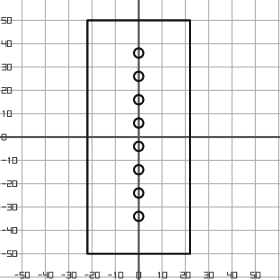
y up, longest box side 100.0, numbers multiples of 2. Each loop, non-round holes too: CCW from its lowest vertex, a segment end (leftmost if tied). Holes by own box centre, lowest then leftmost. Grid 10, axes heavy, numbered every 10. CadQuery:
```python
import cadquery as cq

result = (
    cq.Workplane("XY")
    .moveTo(-22.0, -50.0)
    .lineTo(22.0, -50.0)
    .lineTo(22.0, 50.0)
    .lineTo(-22.0, 50.0)
    .close()
    .moveTo(0.0, -34.0)
    .circle(2.0)
    .moveTo(0.0, -24.0)
    .circle(2.0)
    .moveTo(0.0, -14.0)
    .circle(2.0)
    .moveTo(0.0, -4.0)
    .circle(2.0)
    .moveTo(0.0, 6.0)
    .circle(2.0)
    .moveTo(0.0, 16.0)
    .circle(2.0)
    .moveTo(0.0, 26.0)
    .circle(2.0)
    .moveTo(0.0, 36.0)
    .circle(2.0)
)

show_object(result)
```